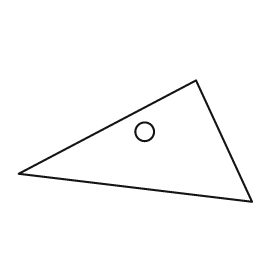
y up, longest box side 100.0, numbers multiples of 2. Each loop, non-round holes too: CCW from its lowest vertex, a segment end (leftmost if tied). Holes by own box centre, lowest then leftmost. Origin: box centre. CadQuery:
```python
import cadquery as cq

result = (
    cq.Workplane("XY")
    .moveTo(50.0, -26.0)
    .lineTo(26.0, 26.0)
    .lineTo(-50.0, -14.0)
    .close()
    .moveTo(4.0, 4.0)
    .circle(4.0)
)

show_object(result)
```